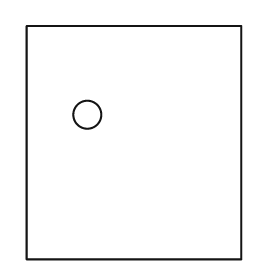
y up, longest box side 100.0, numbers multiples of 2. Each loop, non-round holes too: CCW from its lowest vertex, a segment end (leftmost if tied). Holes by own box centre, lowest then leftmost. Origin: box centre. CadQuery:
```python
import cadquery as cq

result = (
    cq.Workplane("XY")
    .moveTo(-46.0, -50.0)
    .lineTo(46.0, -50.0)
    .lineTo(46.0, 50.0)
    .lineTo(-46.0, 50.0)
    .close()
    .moveTo(-20.0, 12.0)
    .circle(6.0)
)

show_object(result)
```